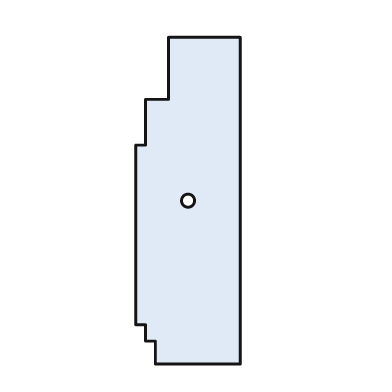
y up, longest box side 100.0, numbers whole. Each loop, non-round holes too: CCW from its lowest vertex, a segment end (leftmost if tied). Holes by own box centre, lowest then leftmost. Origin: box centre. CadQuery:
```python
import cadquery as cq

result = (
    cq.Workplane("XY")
    .moveTo(-10.0, -50.0)
    .lineTo(16.0, -50.0)
    .lineTo(16.0, 50.0)
    .lineTo(-6.0, 50.0)
    .lineTo(-6.0, 31.0)
    .lineTo(-13.0, 31.0)
    .lineTo(-13.0, 17.0)
    .lineTo(-16.0, 17.0)
    .lineTo(-16.0, -38.0)
    .lineTo(-13.0, -38.0)
    .lineTo(-13.0, -43.0)
    .lineTo(-10.0, -43.0)
    .close()
    .moveTo(0.0, 0.0)
    .circle(2.0)
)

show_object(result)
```